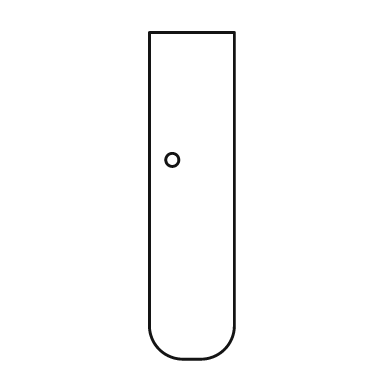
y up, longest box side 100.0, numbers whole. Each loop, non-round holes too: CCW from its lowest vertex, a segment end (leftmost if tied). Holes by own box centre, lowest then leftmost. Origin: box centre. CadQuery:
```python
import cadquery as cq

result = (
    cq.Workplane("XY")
    .moveTo(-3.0, -50.0)
    .lineTo(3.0, -50.0)
    .threePointArc((10.0, -47.0), (13.0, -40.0))
    .lineTo(13.0, 50.0)
    .lineTo(-13.0, 50.0)
    .lineTo(-13.0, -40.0)
    .threePointArc((-10.0, -47.0), (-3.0, -50.0))
    .close()
    .moveTo(-6.0, 11.0)
    .circle(2.0)
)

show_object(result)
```